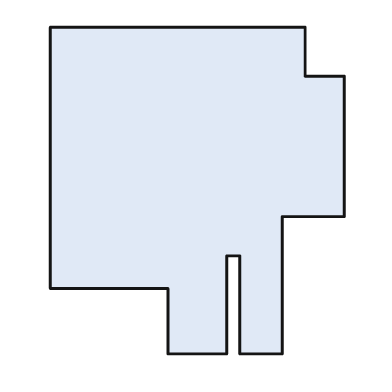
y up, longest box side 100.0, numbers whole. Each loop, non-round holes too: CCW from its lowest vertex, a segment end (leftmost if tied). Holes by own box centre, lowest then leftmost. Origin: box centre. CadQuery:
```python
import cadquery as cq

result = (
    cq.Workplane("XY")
    .moveTo(-9.0, -50.0)
    .lineTo(9.0, -50.0)
    .lineTo(9.0, -20.0)
    .lineTo(13.0, -20.0)
    .lineTo(13.0, -50.0)
    .lineTo(26.0, -50.0)
    .lineTo(26.0, -8.0)
    .lineTo(45.0, -8.0)
    .lineTo(45.0, 35.0)
    .lineTo(33.0, 35.0)
    .lineTo(33.0, 50.0)
    .lineTo(-45.0, 50.0)
    .lineTo(-45.0, -30.0)
    .lineTo(-9.0, -30.0)
    .close()
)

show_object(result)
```